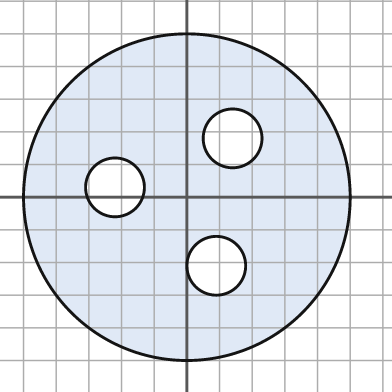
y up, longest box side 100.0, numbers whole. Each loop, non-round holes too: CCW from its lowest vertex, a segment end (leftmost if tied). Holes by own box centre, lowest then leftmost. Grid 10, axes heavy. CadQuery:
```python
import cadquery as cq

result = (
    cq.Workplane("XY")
    .moveTo(0.0, 0.0)
    .circle(50.0)
    .moveTo(9.0, -21.0)
    .circle(9.0)
    .moveTo(-22.0, 3.0)
    .circle(9.0)
    .moveTo(14.0, 18.0)
    .circle(9.0)
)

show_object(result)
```